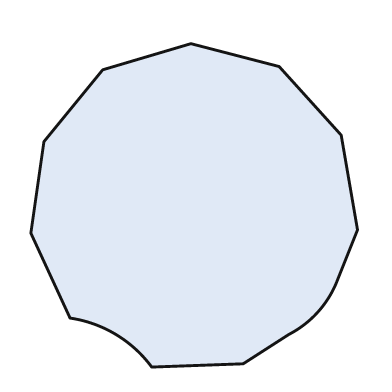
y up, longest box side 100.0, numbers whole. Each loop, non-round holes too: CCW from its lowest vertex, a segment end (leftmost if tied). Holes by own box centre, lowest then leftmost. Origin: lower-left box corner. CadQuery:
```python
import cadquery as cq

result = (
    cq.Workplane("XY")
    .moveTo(37.0, 0.0)
    .lineTo(65.0, 1.0)
    .lineTo(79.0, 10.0)
    .threePointArc((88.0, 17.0), (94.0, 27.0))
    .lineTo(100.0, 42.0)
    .lineTo(95.0, 71.0)
    .lineTo(76.0, 92.0)
    .lineTo(49.0, 99.0)
    .lineTo(22.0, 91.0)
    .lineTo(4.0, 69.0)
    .lineTo(0.0, 41.0)
    .lineTo(12.0, 15.0)
    .threePointArc((26.0, 10.0), (37.0, 0.0))
    .close()
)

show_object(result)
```